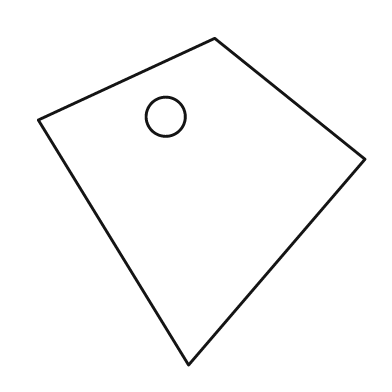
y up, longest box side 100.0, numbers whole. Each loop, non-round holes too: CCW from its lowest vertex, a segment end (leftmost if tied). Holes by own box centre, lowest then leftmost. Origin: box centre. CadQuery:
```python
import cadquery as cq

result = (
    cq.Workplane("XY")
    .moveTo(-4.0, -50.0)
    .lineTo(50.0, 13.0)
    .lineTo(4.0, 50.0)
    .lineTo(-50.0, 25.0)
    .close()
    .moveTo(-11.0, 26.0)
    .circle(6.0)
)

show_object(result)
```